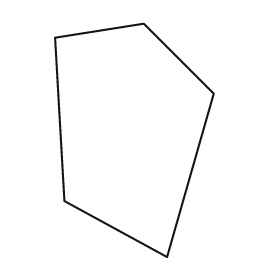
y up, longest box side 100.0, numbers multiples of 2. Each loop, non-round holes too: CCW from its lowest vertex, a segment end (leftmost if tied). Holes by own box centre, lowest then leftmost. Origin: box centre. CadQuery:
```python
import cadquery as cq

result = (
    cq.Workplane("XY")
    .moveTo(14.0, -50.0)
    .lineTo(34.0, 20.0)
    .lineTo(4.0, 50.0)
    .lineTo(-34.0, 44.0)
    .lineTo(-30.0, -26.0)
    .close()
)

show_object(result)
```